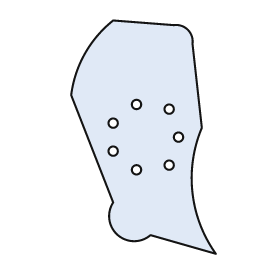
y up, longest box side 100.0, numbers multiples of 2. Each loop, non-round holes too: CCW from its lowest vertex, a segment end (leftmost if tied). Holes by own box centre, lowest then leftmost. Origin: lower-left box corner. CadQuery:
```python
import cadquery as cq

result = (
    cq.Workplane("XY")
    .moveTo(62.0, 0.0)
    .threePointArc((52.0, 26.0), (56.0, 54.0))
    .lineTo(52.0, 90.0)
    .threePointArc((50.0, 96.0), (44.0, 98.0))
    .lineTo(18.0, 100.0)
    .threePointArc((6.0, 86.0), (0.0, 68.0))
    .lineTo(18.0, 22.0)
    .threePointArc((20.0, 8.0), (34.0, 8.0))
    .close()
    .moveTo(28.0, 36.0)
    .circle(2.0)
    .moveTo(42.0, 38.0)
    .circle(2.0)
    .moveTo(18.0, 44.0)
    .circle(2.0)
    .moveTo(46.0, 50.0)
    .circle(2.0)
    .moveTo(18.0, 56.0)
    .circle(2.0)
    .moveTo(42.0, 62.0)
    .circle(2.0)
    .moveTo(28.0, 64.0)
    .circle(2.0)
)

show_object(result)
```